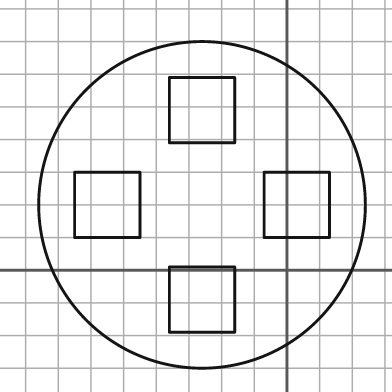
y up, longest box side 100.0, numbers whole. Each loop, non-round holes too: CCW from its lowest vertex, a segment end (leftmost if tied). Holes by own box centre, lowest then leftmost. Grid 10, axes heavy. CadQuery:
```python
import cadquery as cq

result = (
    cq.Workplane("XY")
    .moveTo(-26.0, 20.0)
    .circle(50.0)
    .moveTo(-36.0, -19.0)
    .lineTo(-16.0, -19.0)
    .lineTo(-16.0, 1.0)
    .lineTo(-36.0, 1.0)
    .close()
    .moveTo(-65.0, 10.0)
    .lineTo(-45.0, 10.0)
    .lineTo(-45.0, 30.0)
    .lineTo(-65.0, 30.0)
    .close()
    .moveTo(-7.0, 10.0)
    .lineTo(13.0, 10.0)
    .lineTo(13.0, 30.0)
    .lineTo(-7.0, 30.0)
    .close()
    .moveTo(-36.0, 39.0)
    .lineTo(-16.0, 39.0)
    .lineTo(-16.0, 59.0)
    .lineTo(-36.0, 59.0)
    .close()
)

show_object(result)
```